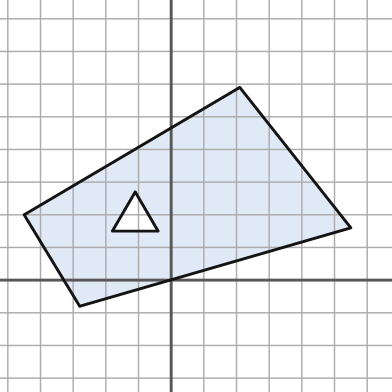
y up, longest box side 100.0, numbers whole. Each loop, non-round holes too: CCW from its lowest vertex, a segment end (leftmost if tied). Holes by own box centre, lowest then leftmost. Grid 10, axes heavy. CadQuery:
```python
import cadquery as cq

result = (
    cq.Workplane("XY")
    .moveTo(-28.0, -8.0)
    .lineTo(55.0, 16.0)
    .lineTo(21.0, 59.0)
    .lineTo(-45.0, 20.0)
    .close()
    .moveTo(-18.0, 15.0)
    .lineTo(-4.0, 15.0)
    .lineTo(-11.0, 27.0)
    .close()
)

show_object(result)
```